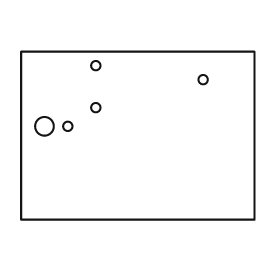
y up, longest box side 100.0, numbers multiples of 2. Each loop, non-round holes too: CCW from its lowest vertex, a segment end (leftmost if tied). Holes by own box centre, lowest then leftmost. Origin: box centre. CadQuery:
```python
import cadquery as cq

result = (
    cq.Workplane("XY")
    .moveTo(-50.0, -36.0)
    .lineTo(50.0, -36.0)
    .lineTo(50.0, 36.0)
    .lineTo(-50.0, 36.0)
    .close()
    .moveTo(-40.0, 4.0)
    .circle(4.0)
    .moveTo(-30.0, 4.0)
    .circle(2.0)
    .moveTo(-18.0, 12.0)
    .circle(2.0)
    .moveTo(28.0, 24.0)
    .circle(2.0)
    .moveTo(-18.0, 30.0)
    .circle(2.0)
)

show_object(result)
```